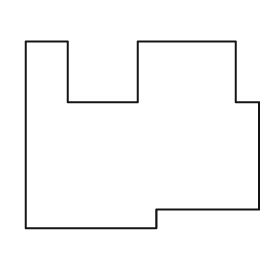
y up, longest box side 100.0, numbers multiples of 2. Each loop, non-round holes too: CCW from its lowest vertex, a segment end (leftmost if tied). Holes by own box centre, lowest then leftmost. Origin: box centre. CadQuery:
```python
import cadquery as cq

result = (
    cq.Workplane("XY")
    .moveTo(-50.0, -40.0)
    .lineTo(6.0, -40.0)
    .lineTo(6.0, -32.0)
    .lineTo(50.0, -32.0)
    .lineTo(50.0, 14.0)
    .lineTo(40.0, 14.0)
    .lineTo(40.0, 40.0)
    .lineTo(-2.0, 40.0)
    .lineTo(-2.0, 14.0)
    .lineTo(-32.0, 14.0)
    .lineTo(-32.0, 40.0)
    .lineTo(-50.0, 40.0)
    .close()
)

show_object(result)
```